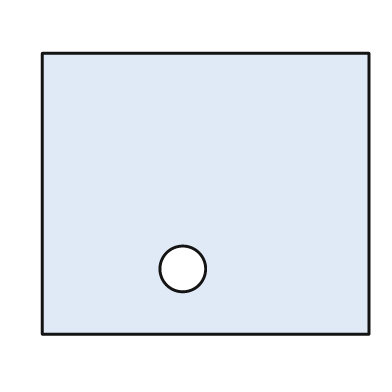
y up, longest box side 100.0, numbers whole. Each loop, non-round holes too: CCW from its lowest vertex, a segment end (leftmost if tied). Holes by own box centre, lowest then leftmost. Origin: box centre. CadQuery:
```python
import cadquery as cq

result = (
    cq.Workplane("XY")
    .moveTo(-50.0, -43.0)
    .lineTo(50.0, -43.0)
    .lineTo(50.0, 43.0)
    .lineTo(-50.0, 43.0)
    .close()
    .moveTo(-7.0, -23.0)
    .circle(7.0)
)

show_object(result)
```